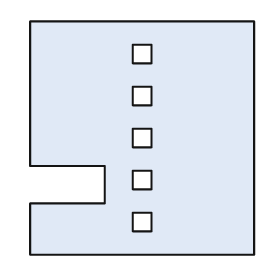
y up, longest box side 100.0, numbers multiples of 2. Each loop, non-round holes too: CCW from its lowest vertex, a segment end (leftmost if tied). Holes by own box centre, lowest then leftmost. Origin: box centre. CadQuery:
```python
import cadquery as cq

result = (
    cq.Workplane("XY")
    .moveTo(-48.0, -50.0)
    .lineTo(48.0, -50.0)
    .lineTo(48.0, 50.0)
    .lineTo(-48.0, 50.0)
    .lineTo(-48.0, -12.0)
    .lineTo(-16.0, -12.0)
    .lineTo(-16.0, -28.0)
    .lineTo(-48.0, -28.0)
    .close()
    .moveTo(-4.0, -40.0)
    .lineTo(4.0, -40.0)
    .lineTo(4.0, -32.0)
    .lineTo(-4.0, -32.0)
    .close()
    .moveTo(-4.0, -22.0)
    .lineTo(4.0, -22.0)
    .lineTo(4.0, -14.0)
    .lineTo(-4.0, -14.0)
    .close()
    .moveTo(-4.0, -4.0)
    .lineTo(4.0, -4.0)
    .lineTo(4.0, 4.0)
    .lineTo(-4.0, 4.0)
    .close()
    .moveTo(-4.0, 14.0)
    .lineTo(4.0, 14.0)
    .lineTo(4.0, 22.0)
    .lineTo(-4.0, 22.0)
    .close()
    .moveTo(-4.0, 32.0)
    .lineTo(4.0, 32.0)
    .lineTo(4.0, 40.0)
    .lineTo(-4.0, 40.0)
    .close()
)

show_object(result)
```